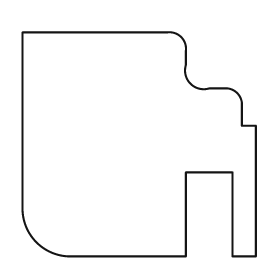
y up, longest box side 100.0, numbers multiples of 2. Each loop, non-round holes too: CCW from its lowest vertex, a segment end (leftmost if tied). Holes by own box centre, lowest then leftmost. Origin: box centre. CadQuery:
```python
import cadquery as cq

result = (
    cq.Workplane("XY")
    .moveTo(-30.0, -48.0)
    .lineTo(20.0, -48.0)
    .lineTo(20.0, -12.0)
    .lineTo(40.0, -12.0)
    .lineTo(40.0, -48.0)
    .lineTo(50.0, -48.0)
    .lineTo(50.0, 8.0)
    .lineTo(44.0, 8.0)
    .lineTo(44.0, 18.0)
    .threePointArc((42.0, 22.0), (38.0, 24.0))
    .lineTo(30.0, 24.0)
    .threePointArc((22.0, 26.0), (20.0, 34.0))
    .lineTo(20.0, 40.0)
    .threePointArc((18.0, 46.0), (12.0, 48.0))
    .lineTo(-50.0, 48.0)
    .lineTo(-50.0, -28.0)
    .threePointArc((-44.0, -42.0), (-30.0, -48.0))
    .close()
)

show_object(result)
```